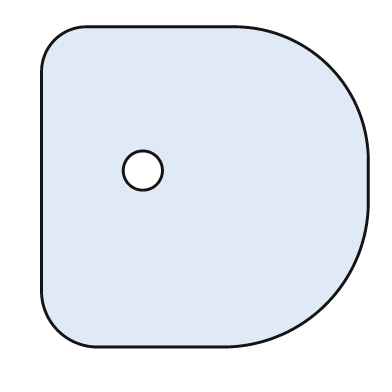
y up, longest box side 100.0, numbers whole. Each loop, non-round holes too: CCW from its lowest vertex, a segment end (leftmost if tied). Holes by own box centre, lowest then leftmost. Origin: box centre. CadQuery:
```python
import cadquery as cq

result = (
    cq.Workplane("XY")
    .moveTo(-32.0, -49.0)
    .lineTo(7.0, -49.0)
    .threePointArc((37.0, -36.0), (50.0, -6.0))
    .lineTo(50.0, 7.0)
    .threePointArc((38.0, 37.0), (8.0, 49.0))
    .lineTo(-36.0, 49.0)
    .threePointArc((-46.0, 45.0), (-50.0, 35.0))
    .lineTo(-50.0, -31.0)
    .threePointArc((-45.0, -44.0), (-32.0, -49.0))
    .close()
    .moveTo(-19.0, 5.0)
    .circle(6.0)
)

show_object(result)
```